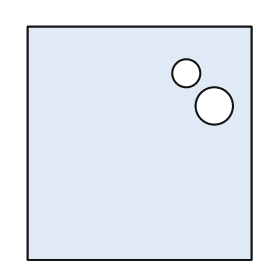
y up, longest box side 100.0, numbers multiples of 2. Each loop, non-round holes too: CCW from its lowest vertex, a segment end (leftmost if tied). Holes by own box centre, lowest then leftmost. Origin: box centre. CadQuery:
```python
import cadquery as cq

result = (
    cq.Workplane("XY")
    .moveTo(-48.0, -50.0)
    .lineTo(48.0, -50.0)
    .lineTo(48.0, 50.0)
    .lineTo(-48.0, 50.0)
    .close()
    .moveTo(32.0, 16.0)
    .circle(8.0)
    .moveTo(20.0, 30.0)
    .circle(6.0)
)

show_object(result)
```